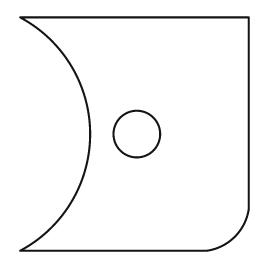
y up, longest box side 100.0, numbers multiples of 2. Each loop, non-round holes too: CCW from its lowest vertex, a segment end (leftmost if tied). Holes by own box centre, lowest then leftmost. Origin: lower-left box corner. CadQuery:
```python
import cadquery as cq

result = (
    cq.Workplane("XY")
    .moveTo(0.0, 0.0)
    .lineTo(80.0, 0.0)
    .threePointArc((92.0, 6.0), (98.0, 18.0))
    .lineTo(98.0, 100.0)
    .lineTo(0.0, 100.0)
    .threePointArc((30.0, 50.0), (0.0, 0.0))
    .close()
    .moveTo(50.0, 50.0)
    .circle(10.0)
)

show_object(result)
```